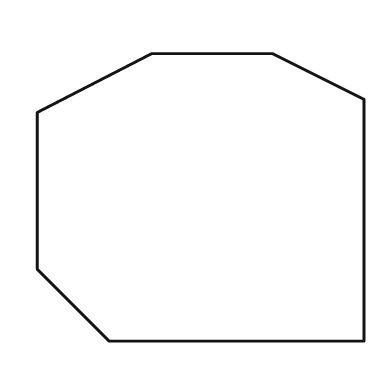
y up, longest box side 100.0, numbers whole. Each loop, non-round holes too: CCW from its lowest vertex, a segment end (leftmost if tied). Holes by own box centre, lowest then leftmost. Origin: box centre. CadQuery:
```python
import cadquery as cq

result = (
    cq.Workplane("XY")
    .moveTo(-28.0, -44.0)
    .lineTo(50.0, -44.0)
    .lineTo(50.0, 30.0)
    .lineTo(22.0, 44.0)
    .lineTo(-15.0, 44.0)
    .lineTo(-50.0, 26.0)
    .lineTo(-50.0, -22.0)
    .close()
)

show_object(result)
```